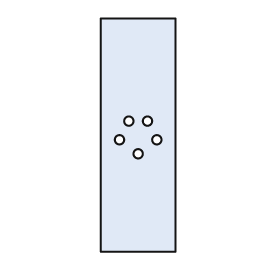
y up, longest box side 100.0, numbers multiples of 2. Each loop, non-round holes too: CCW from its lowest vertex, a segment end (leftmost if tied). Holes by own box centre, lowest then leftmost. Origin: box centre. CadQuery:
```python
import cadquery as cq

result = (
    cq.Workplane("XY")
    .moveTo(-16.0, -50.0)
    .lineTo(16.0, -50.0)
    .lineTo(16.0, 50.0)
    .lineTo(-16.0, 50.0)
    .close()
    .moveTo(0.0, -8.0)
    .circle(2.0)
    .moveTo(-8.0, -2.0)
    .circle(2.0)
    .moveTo(8.0, -2.0)
    .circle(2.0)
    .moveTo(-4.0, 6.0)
    .circle(2.0)
    .moveTo(4.0, 6.0)
    .circle(2.0)
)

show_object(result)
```